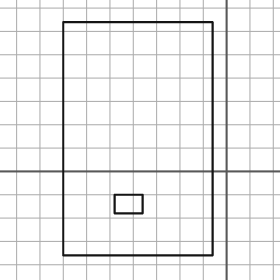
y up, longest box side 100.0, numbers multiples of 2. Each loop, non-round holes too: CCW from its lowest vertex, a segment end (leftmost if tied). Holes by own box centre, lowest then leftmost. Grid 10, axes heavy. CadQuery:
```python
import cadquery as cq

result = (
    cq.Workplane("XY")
    .moveTo(-70.0, -36.0)
    .lineTo(-6.0, -36.0)
    .lineTo(-6.0, 64.0)
    .lineTo(-70.0, 64.0)
    .close()
    .moveTo(-48.0, -18.0)
    .lineTo(-36.0, -18.0)
    .lineTo(-36.0, -10.0)
    .lineTo(-48.0, -10.0)
    .close()
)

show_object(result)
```